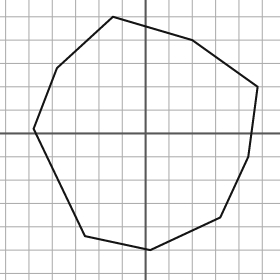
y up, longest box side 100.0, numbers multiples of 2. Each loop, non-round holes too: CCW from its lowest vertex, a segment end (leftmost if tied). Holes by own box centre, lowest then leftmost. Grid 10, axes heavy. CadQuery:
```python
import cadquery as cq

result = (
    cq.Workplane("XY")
    .moveTo(2.0, -50.0)
    .lineTo(32.0, -36.0)
    .lineTo(44.0, -10.0)
    .lineTo(48.0, 20.0)
    .lineTo(20.0, 40.0)
    .lineTo(-14.0, 50.0)
    .lineTo(-38.0, 28.0)
    .lineTo(-48.0, 2.0)
    .lineTo(-26.0, -44.0)
    .close()
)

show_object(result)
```